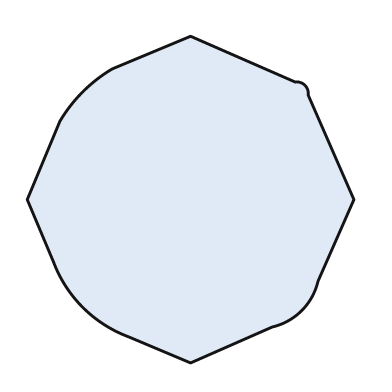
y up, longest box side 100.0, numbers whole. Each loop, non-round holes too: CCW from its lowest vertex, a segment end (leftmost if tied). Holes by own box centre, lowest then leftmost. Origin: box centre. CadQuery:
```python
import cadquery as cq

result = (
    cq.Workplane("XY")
    .moveTo(0.0, -50.0)
    .lineTo(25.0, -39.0)
    .threePointArc((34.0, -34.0), (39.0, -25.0))
    .lineTo(50.0, 0.0)
    .lineTo(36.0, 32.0)
    .threePointArc((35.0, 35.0), (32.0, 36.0))
    .lineTo(0.0, 50.0)
    .lineTo(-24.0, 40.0)
    .threePointArc((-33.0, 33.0), (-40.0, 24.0))
    .lineTo(-50.0, 0.0)
    .lineTo(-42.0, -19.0)
    .threePointArc((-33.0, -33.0), (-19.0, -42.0))
    .close()
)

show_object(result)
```